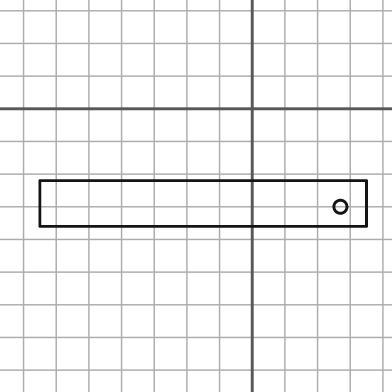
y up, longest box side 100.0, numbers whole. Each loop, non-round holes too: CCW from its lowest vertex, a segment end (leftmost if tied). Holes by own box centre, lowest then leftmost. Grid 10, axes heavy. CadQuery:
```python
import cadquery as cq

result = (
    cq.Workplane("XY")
    .moveTo(-65.0, -36.0)
    .lineTo(35.0, -36.0)
    .lineTo(35.0, -22.0)
    .lineTo(-65.0, -22.0)
    .close()
    .moveTo(27.0, -30.0)
    .circle(2.0)
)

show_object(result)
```